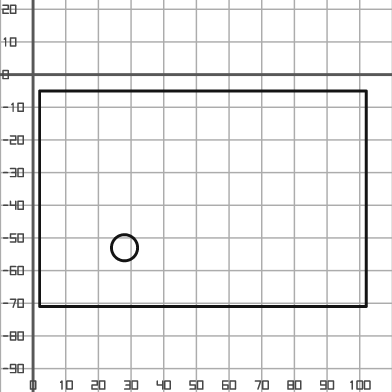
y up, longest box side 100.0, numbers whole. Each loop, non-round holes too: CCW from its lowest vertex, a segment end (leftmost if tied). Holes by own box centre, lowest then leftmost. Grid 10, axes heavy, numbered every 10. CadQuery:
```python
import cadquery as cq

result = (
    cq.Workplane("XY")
    .moveTo(2.0, -71.0)
    .lineTo(102.0, -71.0)
    .lineTo(102.0, -5.0)
    .lineTo(2.0, -5.0)
    .close()
    .moveTo(28.0, -53.0)
    .circle(4.0)
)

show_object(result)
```